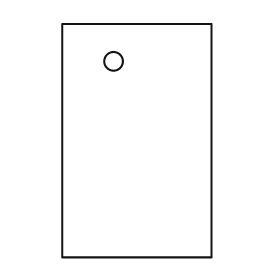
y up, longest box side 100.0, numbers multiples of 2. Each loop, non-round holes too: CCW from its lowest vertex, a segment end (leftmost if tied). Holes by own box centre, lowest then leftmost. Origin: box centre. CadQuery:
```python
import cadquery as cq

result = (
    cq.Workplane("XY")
    .moveTo(-32.0, -50.0)
    .lineTo(32.0, -50.0)
    .lineTo(32.0, 50.0)
    .lineTo(-32.0, 50.0)
    .close()
    .moveTo(-10.0, 34.0)
    .circle(4.0)
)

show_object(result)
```